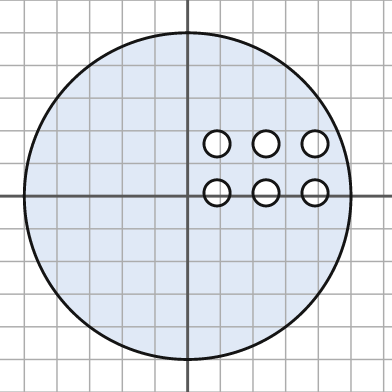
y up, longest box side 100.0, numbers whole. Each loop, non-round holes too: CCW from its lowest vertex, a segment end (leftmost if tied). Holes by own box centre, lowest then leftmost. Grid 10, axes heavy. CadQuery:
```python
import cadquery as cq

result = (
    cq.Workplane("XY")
    .moveTo(0.0, 0.0)
    .circle(50.0)
    .moveTo(9.0, 1.0)
    .circle(4.0)
    .moveTo(24.0, 1.0)
    .circle(4.0)
    .moveTo(39.0, 1.0)
    .circle(4.0)
    .moveTo(9.0, 16.0)
    .circle(4.0)
    .moveTo(24.0, 16.0)
    .circle(4.0)
    .moveTo(39.0, 16.0)
    .circle(4.0)
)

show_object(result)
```